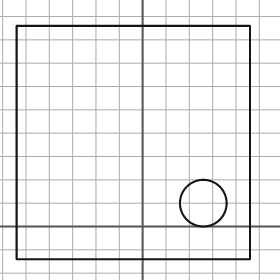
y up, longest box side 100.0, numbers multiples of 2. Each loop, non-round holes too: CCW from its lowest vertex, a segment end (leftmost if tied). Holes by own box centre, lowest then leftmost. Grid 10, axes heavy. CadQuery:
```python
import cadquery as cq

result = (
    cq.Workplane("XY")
    .moveTo(-54.0, -14.0)
    .lineTo(46.0, -14.0)
    .lineTo(46.0, 86.0)
    .lineTo(-54.0, 86.0)
    .close()
    .moveTo(26.0, 10.0)
    .circle(10.0)
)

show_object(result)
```